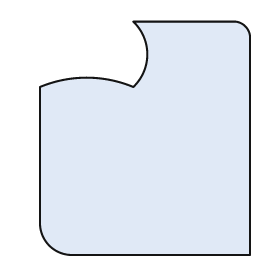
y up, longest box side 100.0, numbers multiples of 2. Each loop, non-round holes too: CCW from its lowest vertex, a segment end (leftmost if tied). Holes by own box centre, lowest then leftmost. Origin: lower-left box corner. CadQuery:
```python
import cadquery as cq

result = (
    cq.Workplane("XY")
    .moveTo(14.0, 0.0)
    .lineTo(90.0, 0.0)
    .lineTo(90.0, 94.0)
    .threePointArc((88.0, 98.0), (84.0, 100.0))
    .lineTo(40.0, 100.0)
    .threePointArc((46.0, 86.0), (40.0, 72.0))
    .threePointArc((20.0, 76.0), (0.0, 72.0))
    .lineTo(0.0, 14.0)
    .threePointArc((4.0, 4.0), (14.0, 0.0))
    .close()
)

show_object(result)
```